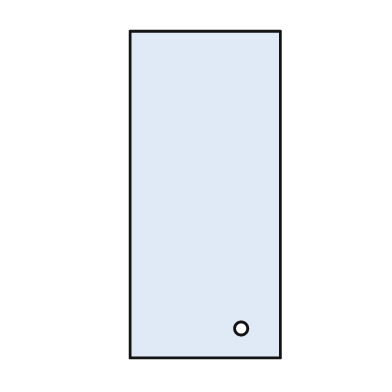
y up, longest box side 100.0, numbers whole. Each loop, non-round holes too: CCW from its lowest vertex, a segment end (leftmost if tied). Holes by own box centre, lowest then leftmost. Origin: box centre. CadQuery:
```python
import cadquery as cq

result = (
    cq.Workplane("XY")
    .moveTo(-23.0, -50.0)
    .lineTo(23.0, -50.0)
    .lineTo(23.0, 50.0)
    .lineTo(-23.0, 50.0)
    .close()
    .moveTo(11.0, -41.0)
    .circle(2.0)
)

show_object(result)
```